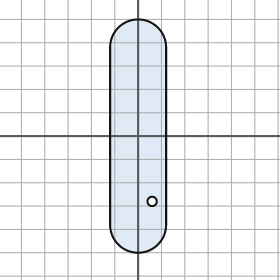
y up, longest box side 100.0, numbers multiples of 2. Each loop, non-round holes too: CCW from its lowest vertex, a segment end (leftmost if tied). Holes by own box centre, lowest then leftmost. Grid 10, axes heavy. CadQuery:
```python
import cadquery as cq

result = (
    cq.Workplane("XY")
    .moveTo(-12.0, -38.0)
    .threePointArc((0.0, -50.0), (12.0, -38.0))
    .lineTo(12.0, 38.0)
    .threePointArc((0.0, 50.0), (-12.0, 38.0))
    .close()
    .moveTo(6.0, -28.0)
    .circle(2.0)
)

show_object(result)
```